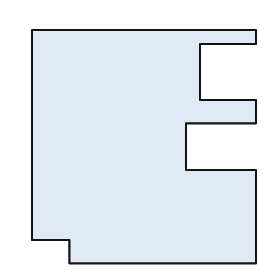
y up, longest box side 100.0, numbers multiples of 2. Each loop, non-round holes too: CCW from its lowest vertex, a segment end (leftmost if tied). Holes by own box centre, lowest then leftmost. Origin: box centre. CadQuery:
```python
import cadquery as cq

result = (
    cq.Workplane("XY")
    .moveTo(-32.0, -50.0)
    .lineTo(48.0, -50.0)
    .lineTo(48.0, -10.0)
    .lineTo(18.0, -10.0)
    .lineTo(18.0, 10.0)
    .lineTo(48.0, 10.0)
    .lineTo(48.0, 20.0)
    .lineTo(24.0, 20.0)
    .lineTo(24.0, 44.0)
    .lineTo(48.0, 44.0)
    .lineTo(48.0, 50.0)
    .lineTo(-48.0, 50.0)
    .lineTo(-48.0, -40.0)
    .lineTo(-32.0, -40.0)
    .close()
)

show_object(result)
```